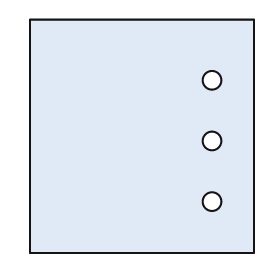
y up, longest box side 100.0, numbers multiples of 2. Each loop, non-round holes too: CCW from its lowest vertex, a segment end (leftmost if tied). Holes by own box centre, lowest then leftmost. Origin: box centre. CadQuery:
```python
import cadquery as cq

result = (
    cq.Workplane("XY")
    .moveTo(-48.0, -50.0)
    .lineTo(48.0, -50.0)
    .lineTo(48.0, 50.0)
    .lineTo(-48.0, 50.0)
    .close()
    .moveTo(30.0, -28.0)
    .circle(4.0)
    .moveTo(30.0, -2.0)
    .circle(4.0)
    .moveTo(30.0, 24.0)
    .circle(4.0)
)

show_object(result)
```